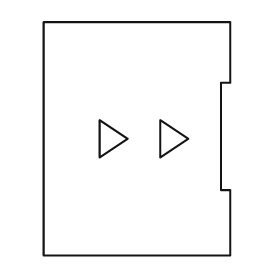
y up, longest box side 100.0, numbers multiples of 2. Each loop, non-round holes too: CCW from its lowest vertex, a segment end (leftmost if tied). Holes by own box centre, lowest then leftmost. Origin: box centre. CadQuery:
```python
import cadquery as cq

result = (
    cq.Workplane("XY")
    .moveTo(-40.0, -50.0)
    .lineTo(40.0, -50.0)
    .lineTo(40.0, -22.0)
    .lineTo(36.0, -22.0)
    .lineTo(36.0, 24.0)
    .lineTo(40.0, 24.0)
    .lineTo(40.0, 50.0)
    .lineTo(-40.0, 50.0)
    .close()
    .moveTo(-16.0, -8.0)
    .lineTo(-4.0, 0.0)
    .lineTo(-16.0, 8.0)
    .close()
    .moveTo(10.0, -8.0)
    .lineTo(22.0, 0.0)
    .lineTo(10.0, 8.0)
    .close()
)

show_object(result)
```